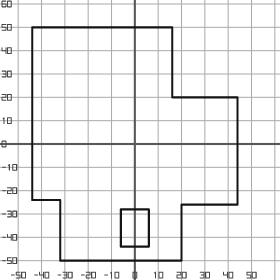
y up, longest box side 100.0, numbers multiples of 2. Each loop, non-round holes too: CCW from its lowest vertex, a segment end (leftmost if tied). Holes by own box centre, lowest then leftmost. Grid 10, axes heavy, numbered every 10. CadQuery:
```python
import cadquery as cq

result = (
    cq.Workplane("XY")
    .moveTo(-32.0, -50.0)
    .lineTo(20.0, -50.0)
    .lineTo(20.0, -26.0)
    .lineTo(44.0, -26.0)
    .lineTo(44.0, 20.0)
    .lineTo(16.0, 20.0)
    .lineTo(16.0, 50.0)
    .lineTo(-44.0, 50.0)
    .lineTo(-44.0, -24.0)
    .lineTo(-32.0, -24.0)
    .close()
    .moveTo(-6.0, -44.0)
    .lineTo(6.0, -44.0)
    .lineTo(6.0, -28.0)
    .lineTo(-6.0, -28.0)
    .close()
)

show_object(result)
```